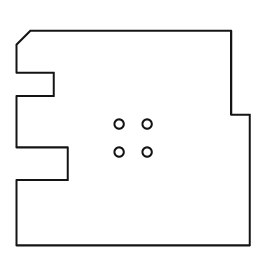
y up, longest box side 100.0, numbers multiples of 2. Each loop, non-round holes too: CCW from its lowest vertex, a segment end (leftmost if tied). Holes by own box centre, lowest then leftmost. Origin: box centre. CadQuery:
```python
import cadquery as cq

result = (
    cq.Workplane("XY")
    .moveTo(-50.0, -46.0)
    .lineTo(50.0, -46.0)
    .lineTo(50.0, 10.0)
    .lineTo(42.0, 10.0)
    .lineTo(42.0, 46.0)
    .lineTo(-44.0, 46.0)
    .lineTo(-50.0, 40.0)
    .lineTo(-50.0, 28.0)
    .lineTo(-34.0, 28.0)
    .lineTo(-34.0, 18.0)
    .lineTo(-50.0, 18.0)
    .lineTo(-50.0, -4.0)
    .lineTo(-28.0, -4.0)
    .lineTo(-28.0, -18.0)
    .lineTo(-50.0, -18.0)
    .close()
    .moveTo(-6.0, -6.0)
    .circle(2.0)
    .moveTo(6.0, -6.0)
    .circle(2.0)
    .moveTo(-6.0, 6.0)
    .circle(2.0)
    .moveTo(6.0, 6.0)
    .circle(2.0)
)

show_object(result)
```